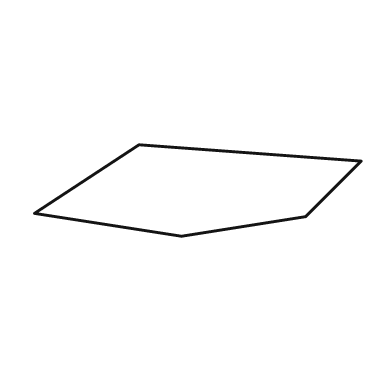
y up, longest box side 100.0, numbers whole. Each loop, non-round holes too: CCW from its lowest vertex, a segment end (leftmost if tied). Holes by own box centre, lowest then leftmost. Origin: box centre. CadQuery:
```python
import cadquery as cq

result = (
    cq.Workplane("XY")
    .moveTo(-5.0, -14.0)
    .lineTo(33.0, -8.0)
    .lineTo(50.0, 9.0)
    .lineTo(-18.0, 14.0)
    .lineTo(-50.0, -7.0)
    .close()
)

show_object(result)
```